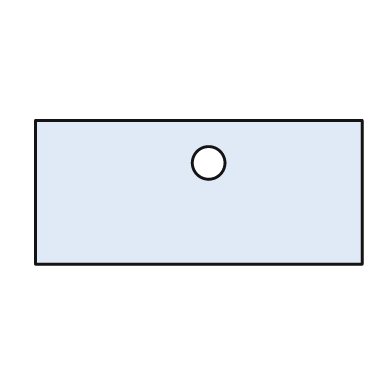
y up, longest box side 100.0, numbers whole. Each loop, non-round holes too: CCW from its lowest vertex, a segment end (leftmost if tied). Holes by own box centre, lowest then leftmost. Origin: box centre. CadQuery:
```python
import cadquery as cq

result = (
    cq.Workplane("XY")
    .moveTo(-50.0, -22.0)
    .lineTo(50.0, -22.0)
    .lineTo(50.0, 22.0)
    .lineTo(-50.0, 22.0)
    .close()
    .moveTo(3.0, 9.0)
    .circle(5.0)
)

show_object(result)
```